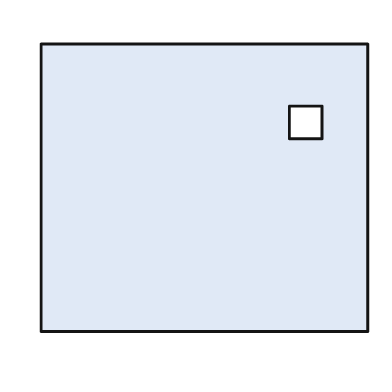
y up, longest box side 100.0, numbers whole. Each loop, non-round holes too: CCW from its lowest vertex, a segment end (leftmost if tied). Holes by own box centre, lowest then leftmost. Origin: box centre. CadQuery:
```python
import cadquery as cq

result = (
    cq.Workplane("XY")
    .moveTo(-50.0, -44.0)
    .lineTo(50.0, -44.0)
    .lineTo(50.0, 44.0)
    .lineTo(-50.0, 44.0)
    .close()
    .moveTo(26.0, 15.0)
    .lineTo(36.0, 15.0)
    .lineTo(36.0, 25.0)
    .lineTo(26.0, 25.0)
    .close()
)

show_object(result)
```